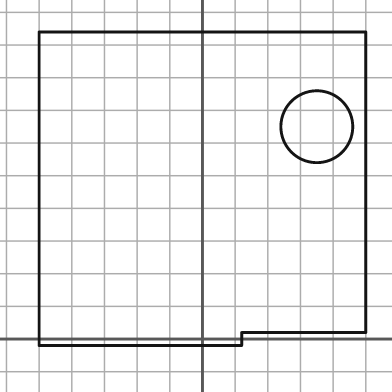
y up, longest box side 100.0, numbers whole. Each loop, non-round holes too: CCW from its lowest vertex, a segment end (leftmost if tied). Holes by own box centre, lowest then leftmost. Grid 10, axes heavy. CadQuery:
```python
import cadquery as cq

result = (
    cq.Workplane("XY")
    .moveTo(-50.0, -2.0)
    .lineTo(12.0, -2.0)
    .lineTo(12.0, 2.0)
    .lineTo(50.0, 2.0)
    .lineTo(50.0, 94.0)
    .lineTo(-50.0, 94.0)
    .close()
    .moveTo(35.0, 65.0)
    .circle(11.0)
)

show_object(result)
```